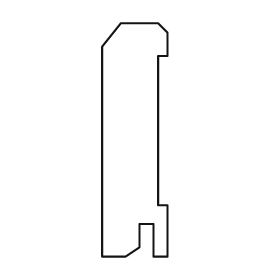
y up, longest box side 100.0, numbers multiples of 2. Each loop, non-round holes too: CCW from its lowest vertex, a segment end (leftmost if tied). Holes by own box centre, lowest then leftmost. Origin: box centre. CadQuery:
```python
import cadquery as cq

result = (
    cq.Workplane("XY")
    .moveTo(-14.0, -50.0)
    .lineTo(-4.0, -50.0)
    .lineTo(2.0, -46.0)
    .lineTo(2.0, -36.0)
    .lineTo(8.0, -36.0)
    .lineTo(8.0, -50.0)
    .lineTo(14.0, -50.0)
    .lineTo(14.0, -28.0)
    .lineTo(10.0, -28.0)
    .lineTo(10.0, 36.0)
    .lineTo(14.0, 36.0)
    .lineTo(14.0, 46.0)
    .lineTo(10.0, 50.0)
    .lineTo(-6.0, 50.0)
    .lineTo(-14.0, 40.0)
    .close()
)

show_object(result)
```